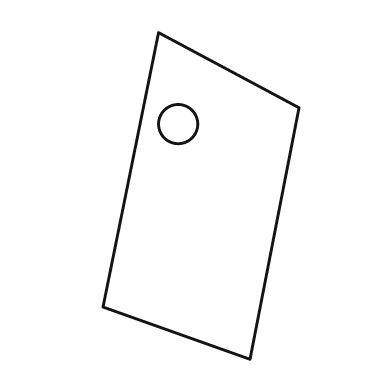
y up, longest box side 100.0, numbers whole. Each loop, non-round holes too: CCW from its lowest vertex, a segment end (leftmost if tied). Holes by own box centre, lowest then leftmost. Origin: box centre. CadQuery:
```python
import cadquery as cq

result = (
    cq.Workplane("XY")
    .moveTo(15.0, -50.0)
    .lineTo(30.0, 27.0)
    .lineTo(-13.0, 50.0)
    .lineTo(-30.0, -34.0)
    .close()
    .moveTo(-7.0, 22.0)
    .circle(6.0)
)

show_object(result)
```